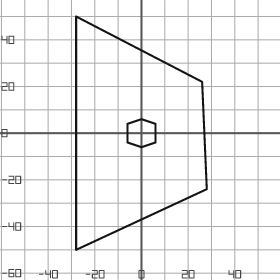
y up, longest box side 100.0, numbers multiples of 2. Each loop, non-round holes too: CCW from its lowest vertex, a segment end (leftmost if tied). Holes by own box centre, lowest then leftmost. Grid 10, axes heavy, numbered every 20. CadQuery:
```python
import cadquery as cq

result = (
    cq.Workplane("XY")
    .moveTo(-28.0, -50.0)
    .lineTo(28.0, -24.0)
    .lineTo(26.0, 22.0)
    .lineTo(-28.0, 50.0)
    .close()
    .moveTo(0.0, -6.0)
    .lineTo(6.0, -4.0)
    .lineTo(6.0, 4.0)
    .lineTo(0.0, 6.0)
    .lineTo(-6.0, 4.0)
    .lineTo(-6.0, -4.0)
    .close()
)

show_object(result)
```